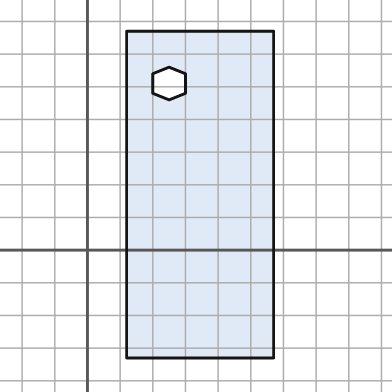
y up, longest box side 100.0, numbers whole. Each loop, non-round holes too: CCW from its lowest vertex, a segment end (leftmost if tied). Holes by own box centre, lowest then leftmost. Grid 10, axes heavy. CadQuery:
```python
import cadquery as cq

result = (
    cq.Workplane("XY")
    .moveTo(12.0, -33.0)
    .lineTo(57.0, -33.0)
    .lineTo(57.0, 67.0)
    .lineTo(12.0, 67.0)
    .close()
    .moveTo(25.0, 46.0)
    .lineTo(30.0, 48.0)
    .lineTo(30.0, 54.0)
    .lineTo(25.0, 56.0)
    .lineTo(20.0, 54.0)
    .lineTo(20.0, 48.0)
    .close()
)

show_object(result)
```